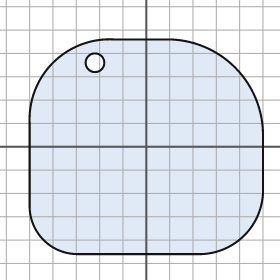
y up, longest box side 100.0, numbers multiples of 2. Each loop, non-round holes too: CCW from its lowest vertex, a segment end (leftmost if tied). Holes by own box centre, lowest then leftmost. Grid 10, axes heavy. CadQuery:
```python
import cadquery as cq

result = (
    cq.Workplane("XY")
    .moveTo(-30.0, -46.0)
    .lineTo(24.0, -46.0)
    .threePointArc((42.0, -38.0), (50.0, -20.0))
    .lineTo(50.0, 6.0)
    .threePointArc((38.0, 34.0), (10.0, 46.0))
    .lineTo(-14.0, 46.0)
    .threePointArc((-40.0, 36.0), (-50.0, 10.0))
    .lineTo(-50.0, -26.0)
    .threePointArc((-44.0, -40.0), (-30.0, -46.0))
    .close()
    .moveTo(-22.0, 36.0)
    .circle(4.0)
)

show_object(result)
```